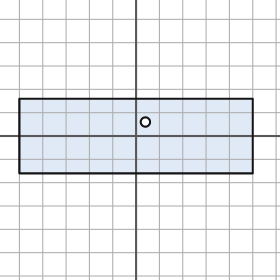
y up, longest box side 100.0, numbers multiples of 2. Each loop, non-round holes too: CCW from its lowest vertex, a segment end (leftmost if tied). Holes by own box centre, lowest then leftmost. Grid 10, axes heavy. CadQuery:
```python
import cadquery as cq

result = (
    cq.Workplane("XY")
    .moveTo(-50.0, -16.0)
    .lineTo(50.0, -16.0)
    .lineTo(50.0, 16.0)
    .lineTo(-50.0, 16.0)
    .close()
    .moveTo(4.0, 6.0)
    .circle(2.0)
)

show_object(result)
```